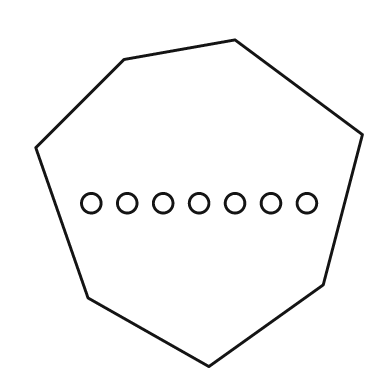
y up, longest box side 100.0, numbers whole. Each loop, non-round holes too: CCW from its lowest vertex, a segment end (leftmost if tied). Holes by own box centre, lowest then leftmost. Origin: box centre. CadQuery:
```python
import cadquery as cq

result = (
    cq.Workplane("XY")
    .moveTo(3.0, -50.0)
    .lineTo(38.0, -25.0)
    .lineTo(50.0, 21.0)
    .lineTo(11.0, 50.0)
    .lineTo(-23.0, 44.0)
    .lineTo(-50.0, 17.0)
    .lineTo(-34.0, -29.0)
    .close()
    .moveTo(-33.0, 0.0)
    .circle(3.0)
    .moveTo(-22.0, 0.0)
    .circle(3.0)
    .moveTo(-11.0, 0.0)
    .circle(3.0)
    .moveTo(0.0, 0.0)
    .circle(3.0)
    .moveTo(11.0, 0.0)
    .circle(3.0)
    .moveTo(22.0, 0.0)
    .circle(3.0)
    .moveTo(33.0, 0.0)
    .circle(3.0)
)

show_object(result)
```